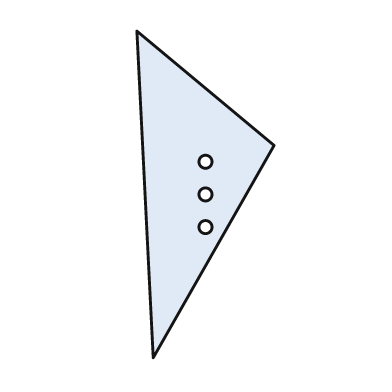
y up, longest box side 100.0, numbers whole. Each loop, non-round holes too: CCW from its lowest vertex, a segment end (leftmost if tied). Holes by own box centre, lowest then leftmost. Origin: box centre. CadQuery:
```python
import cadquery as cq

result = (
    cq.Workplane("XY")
    .moveTo(-16.0, -50.0)
    .lineTo(21.0, 15.0)
    .lineTo(-21.0, 50.0)
    .close()
    .moveTo(0.0, -10.0)
    .circle(2.0)
    .moveTo(0.0, 0.0)
    .circle(2.0)
    .moveTo(0.0, 10.0)
    .circle(2.0)
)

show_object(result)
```